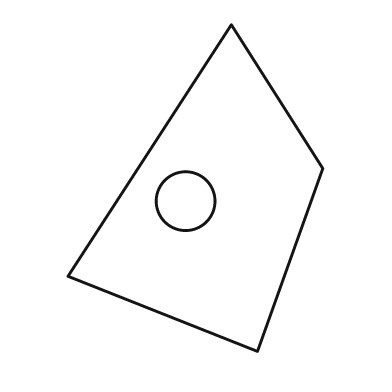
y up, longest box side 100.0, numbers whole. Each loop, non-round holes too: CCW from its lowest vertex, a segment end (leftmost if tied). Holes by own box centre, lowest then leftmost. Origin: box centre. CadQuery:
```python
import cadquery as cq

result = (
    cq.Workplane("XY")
    .moveTo(19.0, -50.0)
    .lineTo(39.0, 6.0)
    .lineTo(11.0, 50.0)
    .lineTo(-39.0, -27.0)
    .close()
    .moveTo(-3.0, -4.0)
    .circle(9.0)
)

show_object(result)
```